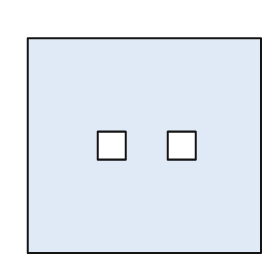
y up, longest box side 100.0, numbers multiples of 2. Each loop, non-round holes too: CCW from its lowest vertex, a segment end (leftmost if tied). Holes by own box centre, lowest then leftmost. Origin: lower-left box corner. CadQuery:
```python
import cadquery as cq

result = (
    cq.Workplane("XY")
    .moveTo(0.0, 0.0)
    .lineTo(100.0, 0.0)
    .lineTo(100.0, 92.0)
    .lineTo(0.0, 92.0)
    .close()
    .moveTo(30.0, 40.0)
    .lineTo(42.0, 40.0)
    .lineTo(42.0, 52.0)
    .lineTo(30.0, 52.0)
    .close()
    .moveTo(60.0, 40.0)
    .lineTo(72.0, 40.0)
    .lineTo(72.0, 52.0)
    .lineTo(60.0, 52.0)
    .close()
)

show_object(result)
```